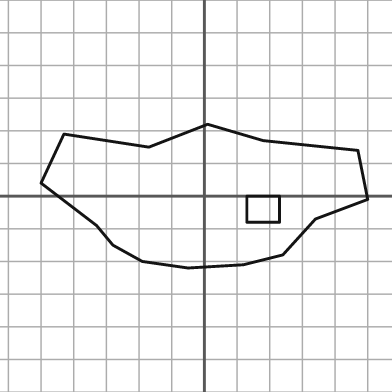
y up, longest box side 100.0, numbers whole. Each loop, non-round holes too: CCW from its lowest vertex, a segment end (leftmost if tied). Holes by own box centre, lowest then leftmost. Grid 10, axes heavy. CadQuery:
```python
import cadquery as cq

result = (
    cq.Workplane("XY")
    .moveTo(-5.0, -22.0)
    .lineTo(12.0, -21.0)
    .lineTo(24.0, -18.0)
    .lineTo(34.0, -7.0)
    .lineTo(50.0, -1.0)
    .lineTo(47.0, 14.0)
    .lineTo(18.0, 17.0)
    .lineTo(1.0, 22.0)
    .lineTo(-17.0, 15.0)
    .lineTo(-43.0, 19.0)
    .lineTo(-50.0, 4.0)
    .lineTo(-33.0, -9.0)
    .lineTo(-28.0, -15.0)
    .lineTo(-19.0, -20.0)
    .close()
    .moveTo(13.0, -8.0)
    .lineTo(23.0, -8.0)
    .lineTo(23.0, 0.0)
    .lineTo(13.0, 0.0)
    .close()
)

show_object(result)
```